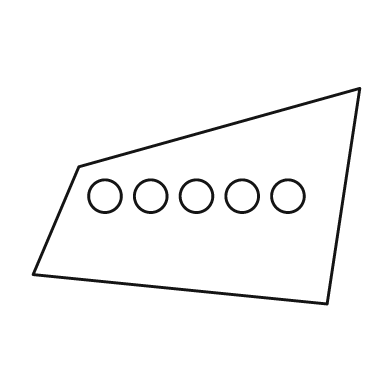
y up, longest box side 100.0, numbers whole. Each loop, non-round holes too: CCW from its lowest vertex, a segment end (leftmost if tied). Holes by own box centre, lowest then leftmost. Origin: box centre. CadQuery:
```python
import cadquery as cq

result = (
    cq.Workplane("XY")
    .moveTo(40.0, -33.0)
    .lineTo(50.0, 33.0)
    .lineTo(-36.0, 9.0)
    .lineTo(-50.0, -24.0)
    .close()
    .moveTo(-28.0, 0.0)
    .circle(5.0)
    .moveTo(-14.0, 0.0)
    .circle(5.0)
    .moveTo(0.0, 0.0)
    .circle(5.0)
    .moveTo(14.0, 0.0)
    .circle(5.0)
    .moveTo(28.0, 0.0)
    .circle(5.0)
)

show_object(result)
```